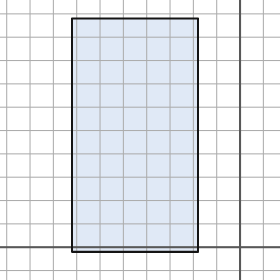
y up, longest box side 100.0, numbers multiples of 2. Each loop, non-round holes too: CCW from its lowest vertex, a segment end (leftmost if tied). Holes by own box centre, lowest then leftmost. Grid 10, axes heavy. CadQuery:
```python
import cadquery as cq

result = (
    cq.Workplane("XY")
    .moveTo(-72.0, -2.0)
    .lineTo(-18.0, -2.0)
    .lineTo(-18.0, 98.0)
    .lineTo(-72.0, 98.0)
    .close()
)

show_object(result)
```